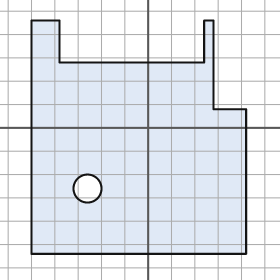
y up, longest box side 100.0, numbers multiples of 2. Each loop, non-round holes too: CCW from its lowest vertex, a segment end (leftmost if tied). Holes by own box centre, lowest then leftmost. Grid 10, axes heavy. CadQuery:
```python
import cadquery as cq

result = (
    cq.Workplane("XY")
    .moveTo(-50.0, -54.0)
    .lineTo(42.0, -54.0)
    .lineTo(42.0, 8.0)
    .lineTo(28.0, 8.0)
    .lineTo(28.0, 46.0)
    .lineTo(24.0, 46.0)
    .lineTo(24.0, 28.0)
    .lineTo(-38.0, 28.0)
    .lineTo(-38.0, 46.0)
    .lineTo(-50.0, 46.0)
    .close()
    .moveTo(-26.0, -26.0)
    .circle(6.0)
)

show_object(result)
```